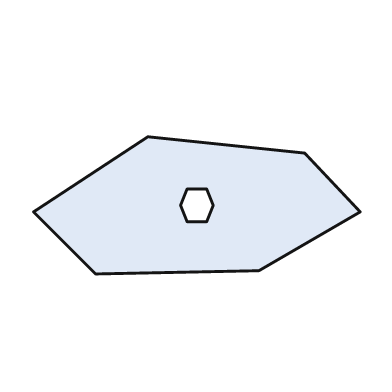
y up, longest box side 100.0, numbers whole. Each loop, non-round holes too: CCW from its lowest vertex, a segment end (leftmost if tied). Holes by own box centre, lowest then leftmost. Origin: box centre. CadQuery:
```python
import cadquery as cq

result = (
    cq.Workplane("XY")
    .moveTo(-31.0, -21.0)
    .lineTo(19.0, -20.0)
    .lineTo(50.0, -2.0)
    .lineTo(33.0, 16.0)
    .lineTo(-15.0, 21.0)
    .lineTo(-50.0, -2.0)
    .close()
    .moveTo(-3.0, -5.0)
    .lineTo(3.0, -5.0)
    .lineTo(5.0, 0.0)
    .lineTo(3.0, 5.0)
    .lineTo(-3.0, 5.0)
    .lineTo(-5.0, 0.0)
    .close()
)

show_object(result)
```